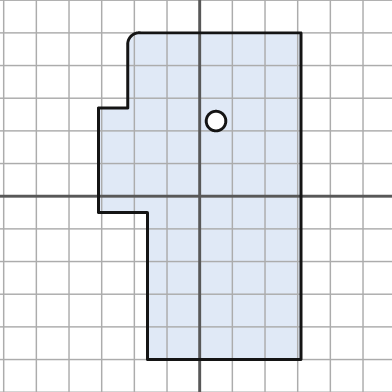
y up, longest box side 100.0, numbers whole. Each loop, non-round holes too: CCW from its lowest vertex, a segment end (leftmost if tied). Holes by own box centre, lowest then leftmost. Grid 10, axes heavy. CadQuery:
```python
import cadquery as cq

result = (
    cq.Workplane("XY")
    .moveTo(-16.0, -50.0)
    .lineTo(31.0, -50.0)
    .lineTo(31.0, 50.0)
    .lineTo(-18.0, 50.0)
    .threePointArc((-21.0, 49.0), (-22.0, 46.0))
    .lineTo(-22.0, 27.0)
    .lineTo(-31.0, 27.0)
    .lineTo(-31.0, -5.0)
    .lineTo(-16.0, -5.0)
    .close()
    .moveTo(5.0, 23.0)
    .circle(3.0)
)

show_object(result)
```